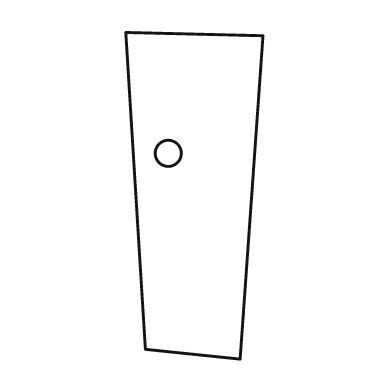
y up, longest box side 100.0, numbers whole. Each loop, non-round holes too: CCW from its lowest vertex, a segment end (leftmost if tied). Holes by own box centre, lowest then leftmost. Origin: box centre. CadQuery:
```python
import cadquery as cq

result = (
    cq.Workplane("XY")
    .moveTo(14.0, -50.0)
    .lineTo(21.0, 49.0)
    .lineTo(-21.0, 50.0)
    .lineTo(-15.0, -47.0)
    .close()
    .moveTo(-8.0, 13.0)
    .circle(4.0)
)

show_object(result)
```